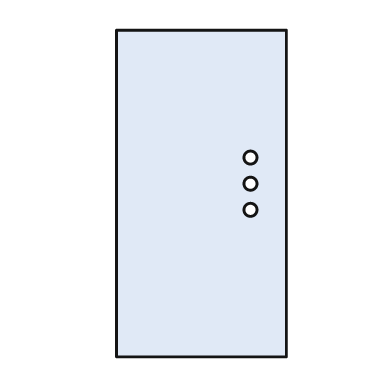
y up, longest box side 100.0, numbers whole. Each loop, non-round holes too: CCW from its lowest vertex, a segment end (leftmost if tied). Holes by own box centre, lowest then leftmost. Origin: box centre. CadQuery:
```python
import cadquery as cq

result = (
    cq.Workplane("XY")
    .moveTo(-26.0, -50.0)
    .lineTo(26.0, -50.0)
    .lineTo(26.0, 50.0)
    .lineTo(-26.0, 50.0)
    .close()
    .moveTo(15.0, -5.0)
    .circle(2.0)
    .moveTo(15.0, 3.0)
    .circle(2.0)
    .moveTo(15.0, 11.0)
    .circle(2.0)
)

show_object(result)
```